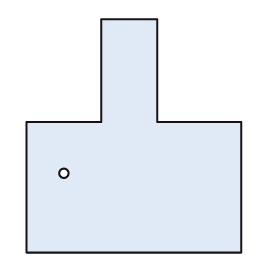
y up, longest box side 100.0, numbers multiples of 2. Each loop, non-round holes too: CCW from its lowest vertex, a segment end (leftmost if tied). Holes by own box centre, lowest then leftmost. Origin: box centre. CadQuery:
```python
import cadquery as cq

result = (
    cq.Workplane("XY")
    .moveTo(-46.0, -50.0)
    .lineTo(46.0, -50.0)
    .lineTo(46.0, 6.0)
    .lineTo(10.0, 6.0)
    .lineTo(10.0, 50.0)
    .lineTo(-14.0, 50.0)
    .lineTo(-14.0, 6.0)
    .lineTo(-46.0, 6.0)
    .close()
    .moveTo(-30.0, -16.0)
    .circle(2.0)
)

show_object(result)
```